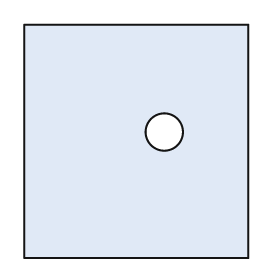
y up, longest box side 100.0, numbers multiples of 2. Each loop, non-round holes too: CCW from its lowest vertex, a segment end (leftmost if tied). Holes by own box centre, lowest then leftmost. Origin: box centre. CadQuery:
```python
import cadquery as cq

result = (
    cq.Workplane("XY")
    .moveTo(-48.0, -50.0)
    .lineTo(48.0, -50.0)
    .lineTo(48.0, 50.0)
    .lineTo(-48.0, 50.0)
    .close()
    .moveTo(12.0, 4.0)
    .circle(8.0)
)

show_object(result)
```